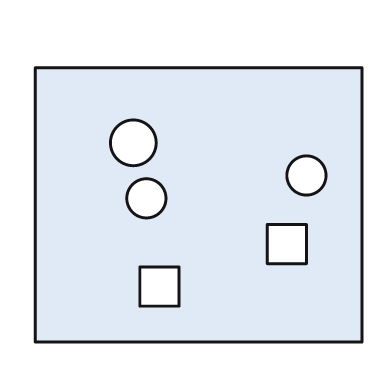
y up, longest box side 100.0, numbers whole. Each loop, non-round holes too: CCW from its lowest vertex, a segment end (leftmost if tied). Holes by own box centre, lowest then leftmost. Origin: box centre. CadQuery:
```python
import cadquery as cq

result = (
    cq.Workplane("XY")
    .moveTo(-50.0, -42.0)
    .lineTo(50.0, -42.0)
    .lineTo(50.0, 42.0)
    .lineTo(-50.0, 42.0)
    .close()
    .moveTo(-18.0, -31.0)
    .lineTo(-6.0, -31.0)
    .lineTo(-6.0, -19.0)
    .lineTo(-18.0, -19.0)
    .close()
    .moveTo(21.0, -18.0)
    .lineTo(33.0, -18.0)
    .lineTo(33.0, -6.0)
    .lineTo(21.0, -6.0)
    .close()
    .moveTo(-16.0, 2.0)
    .circle(6.0)
    .moveTo(33.0, 9.0)
    .circle(6.0)
    .moveTo(-20.0, 19.0)
    .circle(7.0)
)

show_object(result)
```